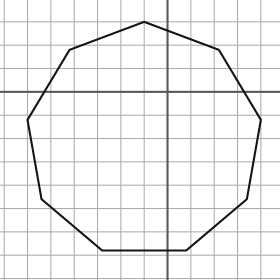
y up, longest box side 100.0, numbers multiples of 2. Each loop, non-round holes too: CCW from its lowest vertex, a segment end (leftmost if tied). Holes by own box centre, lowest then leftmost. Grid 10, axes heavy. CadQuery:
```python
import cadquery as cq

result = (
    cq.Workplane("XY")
    .moveTo(-28.0, -68.0)
    .lineTo(8.0, -68.0)
    .lineTo(34.0, -46.0)
    .lineTo(40.0, -12.0)
    .lineTo(22.0, 18.0)
    .lineTo(-10.0, 30.0)
    .lineTo(-42.0, 18.0)
    .lineTo(-60.0, -12.0)
    .lineTo(-54.0, -46.0)
    .close()
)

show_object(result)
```